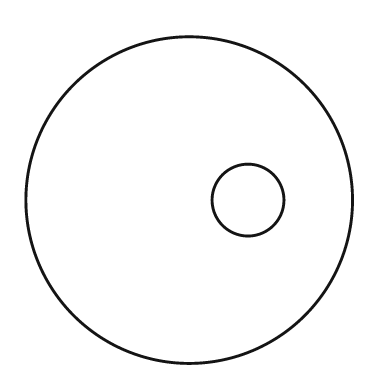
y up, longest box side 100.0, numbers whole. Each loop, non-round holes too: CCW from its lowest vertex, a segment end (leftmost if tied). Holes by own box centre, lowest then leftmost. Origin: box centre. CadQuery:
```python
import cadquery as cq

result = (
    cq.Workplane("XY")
    .moveTo(0.0, 0.0)
    .circle(50.0)
    .moveTo(18.0, 0.0)
    .circle(11.0)
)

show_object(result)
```